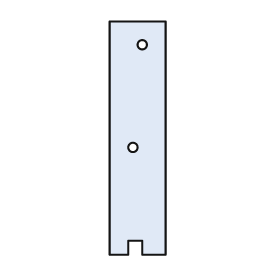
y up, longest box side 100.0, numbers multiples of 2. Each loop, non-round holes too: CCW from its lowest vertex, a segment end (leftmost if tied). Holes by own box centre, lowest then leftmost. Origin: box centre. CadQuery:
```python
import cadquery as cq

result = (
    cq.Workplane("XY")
    .moveTo(-12.0, -50.0)
    .lineTo(-4.0, -50.0)
    .lineTo(-4.0, -44.0)
    .lineTo(2.0, -44.0)
    .lineTo(2.0, -50.0)
    .lineTo(12.0, -50.0)
    .lineTo(12.0, 50.0)
    .lineTo(-12.0, 50.0)
    .close()
    .moveTo(-2.0, -4.0)
    .circle(2.0)
    .moveTo(2.0, 40.0)
    .circle(2.0)
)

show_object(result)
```